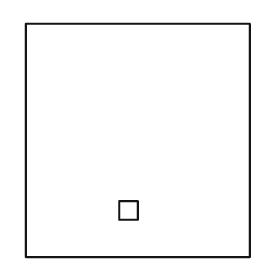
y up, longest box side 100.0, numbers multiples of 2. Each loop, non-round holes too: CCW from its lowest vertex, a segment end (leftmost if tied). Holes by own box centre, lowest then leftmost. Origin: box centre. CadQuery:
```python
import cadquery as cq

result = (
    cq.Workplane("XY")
    .moveTo(-48.0, -50.0)
    .lineTo(48.0, -50.0)
    .lineTo(48.0, 50.0)
    .lineTo(-48.0, 50.0)
    .close()
    .moveTo(-8.0, -34.0)
    .lineTo(0.0, -34.0)
    .lineTo(0.0, -26.0)
    .lineTo(-8.0, -26.0)
    .close()
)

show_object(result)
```